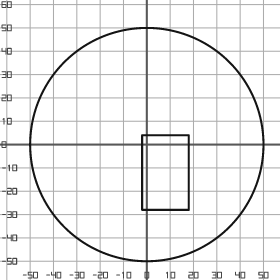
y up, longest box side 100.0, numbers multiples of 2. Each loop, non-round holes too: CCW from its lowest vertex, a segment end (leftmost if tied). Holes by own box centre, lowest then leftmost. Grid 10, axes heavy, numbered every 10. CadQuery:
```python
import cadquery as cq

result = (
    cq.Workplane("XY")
    .moveTo(0.0, 0.0)
    .circle(50.0)
    .moveTo(-2.0, -28.0)
    .lineTo(18.0, -28.0)
    .lineTo(18.0, 4.0)
    .lineTo(-2.0, 4.0)
    .close()
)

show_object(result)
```